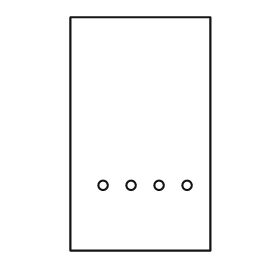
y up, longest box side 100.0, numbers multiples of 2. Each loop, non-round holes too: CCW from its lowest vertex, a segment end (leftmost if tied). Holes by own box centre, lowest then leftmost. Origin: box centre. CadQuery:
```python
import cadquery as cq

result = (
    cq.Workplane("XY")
    .moveTo(-30.0, -50.0)
    .lineTo(30.0, -50.0)
    .lineTo(30.0, 50.0)
    .lineTo(-30.0, 50.0)
    .close()
    .moveTo(-16.0, -22.0)
    .circle(2.0)
    .moveTo(-4.0, -22.0)
    .circle(2.0)
    .moveTo(8.0, -22.0)
    .circle(2.0)
    .moveTo(20.0, -22.0)
    .circle(2.0)
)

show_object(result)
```